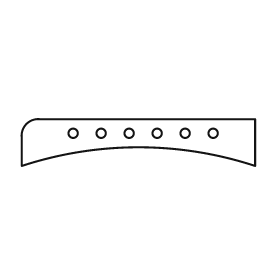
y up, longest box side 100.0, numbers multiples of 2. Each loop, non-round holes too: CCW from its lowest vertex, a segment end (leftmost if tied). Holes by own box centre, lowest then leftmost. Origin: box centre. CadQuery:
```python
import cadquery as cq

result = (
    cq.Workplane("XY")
    .moveTo(-50.0, -10.0)
    .threePointArc((0.0, -2.0), (50.0, -10.0))
    .lineTo(50.0, 10.0)
    .lineTo(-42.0, 10.0)
    .threePointArc((-48.0, 8.0), (-50.0, 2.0))
    .close()
    .moveTo(-28.0, 4.0)
    .circle(2.0)
    .moveTo(-16.0, 4.0)
    .circle(2.0)
    .moveTo(-4.0, 4.0)
    .circle(2.0)
    .moveTo(8.0, 4.0)
    .circle(2.0)
    .moveTo(20.0, 4.0)
    .circle(2.0)
    .moveTo(32.0, 4.0)
    .circle(2.0)
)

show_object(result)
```